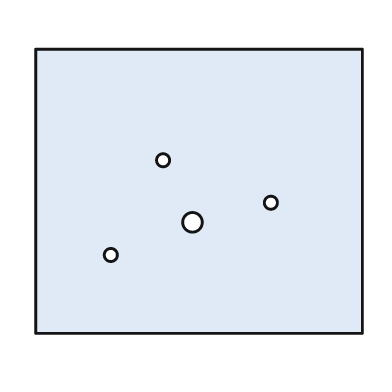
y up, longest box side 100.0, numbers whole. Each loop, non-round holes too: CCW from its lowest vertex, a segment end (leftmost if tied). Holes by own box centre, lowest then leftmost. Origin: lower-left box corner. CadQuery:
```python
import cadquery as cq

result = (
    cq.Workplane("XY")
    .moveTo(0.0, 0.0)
    .lineTo(100.0, 0.0)
    .lineTo(100.0, 87.0)
    .lineTo(0.0, 87.0)
    .close()
    .moveTo(23.0, 24.0)
    .circle(2.0)
    .moveTo(48.0, 34.0)
    .circle(3.0)
    .moveTo(72.0, 40.0)
    .circle(2.0)
    .moveTo(39.0, 53.0)
    .circle(2.0)
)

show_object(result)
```